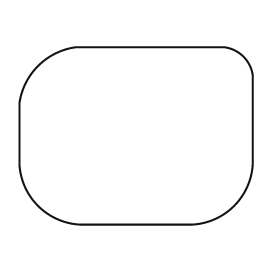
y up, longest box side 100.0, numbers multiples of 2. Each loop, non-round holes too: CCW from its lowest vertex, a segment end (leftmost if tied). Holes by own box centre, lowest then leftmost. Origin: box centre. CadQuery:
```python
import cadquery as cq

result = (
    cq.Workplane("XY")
    .moveTo(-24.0, -38.0)
    .lineTo(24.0, -38.0)
    .threePointArc((42.0, -30.0), (50.0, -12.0))
    .lineTo(50.0, 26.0)
    .threePointArc((46.0, 34.0), (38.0, 38.0))
    .lineTo(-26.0, 38.0)
    .threePointArc((-42.0, 30.0), (-50.0, 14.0))
    .lineTo(-50.0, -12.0)
    .threePointArc((-42.0, -30.0), (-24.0, -38.0))
    .close()
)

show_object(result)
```